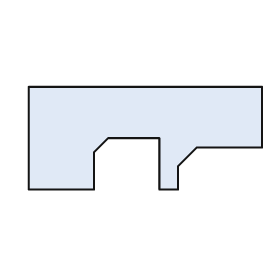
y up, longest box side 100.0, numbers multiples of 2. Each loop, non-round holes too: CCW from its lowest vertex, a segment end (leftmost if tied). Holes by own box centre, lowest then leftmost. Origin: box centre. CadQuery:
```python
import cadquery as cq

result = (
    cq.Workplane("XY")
    .moveTo(-50.0, -22.0)
    .lineTo(-22.0, -22.0)
    .lineTo(-22.0, -6.0)
    .lineTo(-16.0, 0.0)
    .lineTo(6.0, 0.0)
    .lineTo(6.0, -22.0)
    .lineTo(14.0, -22.0)
    .lineTo(14.0, -12.0)
    .lineTo(22.0, -4.0)
    .lineTo(50.0, -4.0)
    .lineTo(50.0, 22.0)
    .lineTo(-50.0, 22.0)
    .close()
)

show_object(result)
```